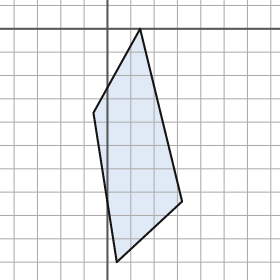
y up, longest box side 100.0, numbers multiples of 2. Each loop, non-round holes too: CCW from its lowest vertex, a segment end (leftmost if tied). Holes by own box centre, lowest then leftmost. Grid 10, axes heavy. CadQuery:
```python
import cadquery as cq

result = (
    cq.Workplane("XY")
    .moveTo(4.0, -100.0)
    .lineTo(32.0, -74.0)
    .lineTo(14.0, 0.0)
    .lineTo(-6.0, -36.0)
    .close()
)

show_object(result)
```